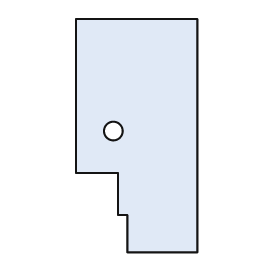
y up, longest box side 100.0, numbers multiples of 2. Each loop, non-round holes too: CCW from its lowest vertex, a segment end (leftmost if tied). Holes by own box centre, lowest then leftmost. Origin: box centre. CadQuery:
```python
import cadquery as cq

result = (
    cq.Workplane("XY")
    .moveTo(-4.0, -50.0)
    .lineTo(26.0, -50.0)
    .lineTo(26.0, 50.0)
    .lineTo(-26.0, 50.0)
    .lineTo(-26.0, -16.0)
    .lineTo(-8.0, -16.0)
    .lineTo(-8.0, -34.0)
    .lineTo(-4.0, -34.0)
    .close()
    .moveTo(-10.0, 2.0)
    .circle(4.0)
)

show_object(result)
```